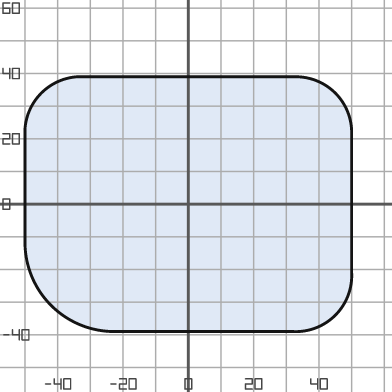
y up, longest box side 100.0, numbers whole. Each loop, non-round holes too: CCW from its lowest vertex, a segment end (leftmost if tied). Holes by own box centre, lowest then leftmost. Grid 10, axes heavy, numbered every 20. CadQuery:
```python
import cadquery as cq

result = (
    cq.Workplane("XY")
    .moveTo(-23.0, -39.0)
    .lineTo(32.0, -39.0)
    .threePointArc((45.0, -34.0), (50.0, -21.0))
    .lineTo(50.0, 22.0)
    .threePointArc((45.0, 34.0), (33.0, 39.0))
    .lineTo(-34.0, 39.0)
    .threePointArc((-45.0, 34.0), (-50.0, 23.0))
    .lineTo(-50.0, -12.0)
    .threePointArc((-42.0, -31.0), (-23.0, -39.0))
    .close()
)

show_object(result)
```